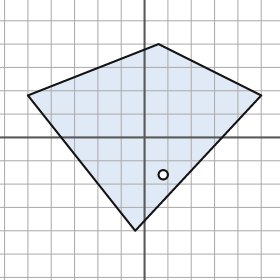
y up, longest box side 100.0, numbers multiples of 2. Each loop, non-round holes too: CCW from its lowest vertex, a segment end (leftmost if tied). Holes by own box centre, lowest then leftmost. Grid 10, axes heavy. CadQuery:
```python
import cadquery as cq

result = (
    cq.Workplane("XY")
    .moveTo(-4.0, -40.0)
    .lineTo(50.0, 18.0)
    .lineTo(6.0, 40.0)
    .lineTo(-50.0, 18.0)
    .close()
    .moveTo(8.0, -16.0)
    .circle(2.0)
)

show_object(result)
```